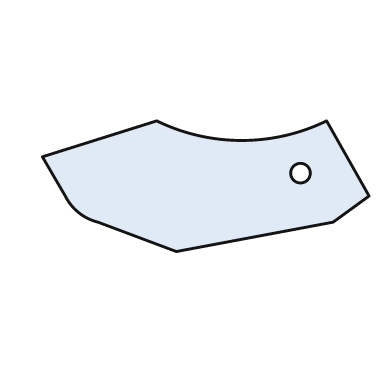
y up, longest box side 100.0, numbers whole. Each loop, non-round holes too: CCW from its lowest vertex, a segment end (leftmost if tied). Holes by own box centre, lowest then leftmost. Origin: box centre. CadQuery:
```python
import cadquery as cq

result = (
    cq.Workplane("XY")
    .moveTo(-9.0, -20.0)
    .lineTo(39.0, -11.0)
    .lineTo(50.0, -3.0)
    .lineTo(37.0, 20.0)
    .threePointArc((11.0, 14.0), (-15.0, 20.0))
    .lineTo(-50.0, 9.0)
    .lineTo(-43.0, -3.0)
    .threePointArc((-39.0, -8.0), (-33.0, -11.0))
    .close()
    .moveTo(29.0, 4.0)
    .circle(3.0)
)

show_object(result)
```